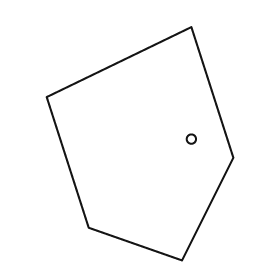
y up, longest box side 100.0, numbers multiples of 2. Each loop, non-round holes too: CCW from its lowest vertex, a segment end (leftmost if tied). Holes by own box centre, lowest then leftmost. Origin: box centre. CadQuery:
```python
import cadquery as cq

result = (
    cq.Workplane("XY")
    .moveTo(18.0, -50.0)
    .lineTo(40.0, -6.0)
    .lineTo(22.0, 50.0)
    .lineTo(-40.0, 20.0)
    .lineTo(-22.0, -36.0)
    .close()
    .moveTo(22.0, 2.0)
    .circle(2.0)
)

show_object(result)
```